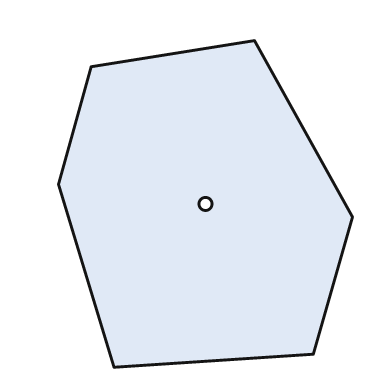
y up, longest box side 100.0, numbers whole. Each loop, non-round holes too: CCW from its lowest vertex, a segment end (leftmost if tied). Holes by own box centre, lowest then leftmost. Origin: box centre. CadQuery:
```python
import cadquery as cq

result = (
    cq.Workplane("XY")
    .moveTo(-28.0, -50.0)
    .lineTo(33.0, -46.0)
    .lineTo(45.0, -4.0)
    .lineTo(15.0, 50.0)
    .lineTo(-35.0, 42.0)
    .lineTo(-45.0, 6.0)
    .close()
    .moveTo(0.0, 0.0)
    .circle(2.0)
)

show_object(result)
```